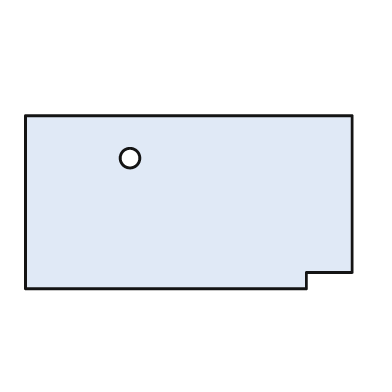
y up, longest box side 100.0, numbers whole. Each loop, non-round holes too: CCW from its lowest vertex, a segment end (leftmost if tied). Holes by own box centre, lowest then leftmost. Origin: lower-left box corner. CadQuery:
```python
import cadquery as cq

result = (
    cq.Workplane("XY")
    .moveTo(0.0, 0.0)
    .lineTo(86.0, 0.0)
    .lineTo(86.0, 5.0)
    .lineTo(100.0, 5.0)
    .lineTo(100.0, 53.0)
    .lineTo(0.0, 53.0)
    .close()
    .moveTo(32.0, 40.0)
    .circle(3.0)
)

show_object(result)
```